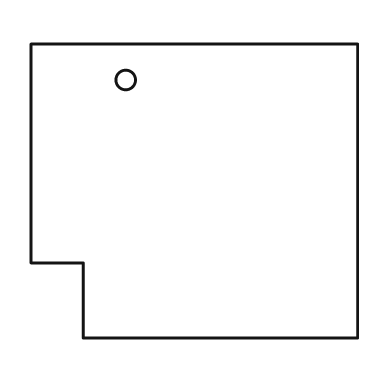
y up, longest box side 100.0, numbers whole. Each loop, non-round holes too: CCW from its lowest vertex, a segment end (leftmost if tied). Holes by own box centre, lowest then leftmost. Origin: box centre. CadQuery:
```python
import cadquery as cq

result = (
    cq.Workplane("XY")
    .moveTo(-34.0, -45.0)
    .lineTo(50.0, -45.0)
    .lineTo(50.0, 45.0)
    .lineTo(-50.0, 45.0)
    .lineTo(-50.0, -22.0)
    .lineTo(-34.0, -22.0)
    .close()
    .moveTo(-21.0, 34.0)
    .circle(3.0)
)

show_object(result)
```